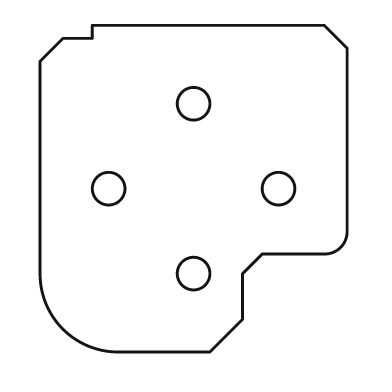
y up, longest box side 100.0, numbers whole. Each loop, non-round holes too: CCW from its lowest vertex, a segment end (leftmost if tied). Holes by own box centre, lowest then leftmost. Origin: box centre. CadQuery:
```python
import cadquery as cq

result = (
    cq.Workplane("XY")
    .moveTo(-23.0, -50.0)
    .lineTo(5.0, -50.0)
    .lineTo(15.0, -40.0)
    .lineTo(15.0, -26.0)
    .lineTo(21.0, -20.0)
    .lineTo(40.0, -20.0)
    .threePointArc((45.0, -18.0), (47.0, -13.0))
    .lineTo(47.0, 43.0)
    .lineTo(40.0, 50.0)
    .lineTo(-31.0, 50.0)
    .lineTo(-31.0, 46.0)
    .lineTo(-40.0, 46.0)
    .lineTo(-47.0, 39.0)
    .lineTo(-47.0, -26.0)
    .threePointArc((-40.0, -43.0), (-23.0, -50.0))
    .close()
    .moveTo(0.0, -26.0)
    .circle(5.0)
    .moveTo(-26.0, 0.0)
    .circle(5.0)
    .moveTo(26.0, 0.0)
    .circle(5.0)
    .moveTo(0.0, 26.0)
    .circle(5.0)
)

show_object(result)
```